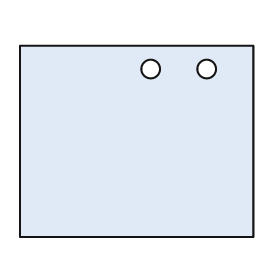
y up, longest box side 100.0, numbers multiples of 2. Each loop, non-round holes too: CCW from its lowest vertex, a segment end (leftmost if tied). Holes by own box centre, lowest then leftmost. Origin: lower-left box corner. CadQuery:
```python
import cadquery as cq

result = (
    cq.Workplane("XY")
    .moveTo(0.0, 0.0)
    .lineTo(100.0, 0.0)
    .lineTo(100.0, 82.0)
    .lineTo(0.0, 82.0)
    .close()
    .moveTo(56.0, 72.0)
    .circle(4.0)
    .moveTo(80.0, 72.0)
    .circle(4.0)
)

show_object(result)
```